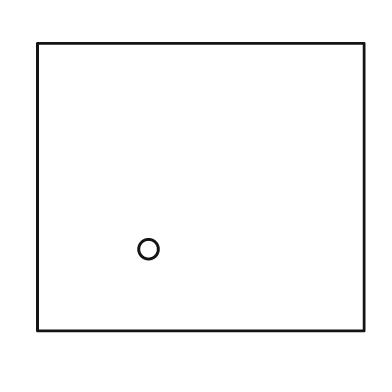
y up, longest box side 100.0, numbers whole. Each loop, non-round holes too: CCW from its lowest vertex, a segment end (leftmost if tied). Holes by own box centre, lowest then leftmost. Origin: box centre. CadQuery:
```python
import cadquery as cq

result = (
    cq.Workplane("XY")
    .moveTo(-50.0, -44.0)
    .lineTo(50.0, -44.0)
    .lineTo(50.0, 44.0)
    .lineTo(-50.0, 44.0)
    .close()
    .moveTo(-16.0, -19.0)
    .circle(3.0)
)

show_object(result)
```